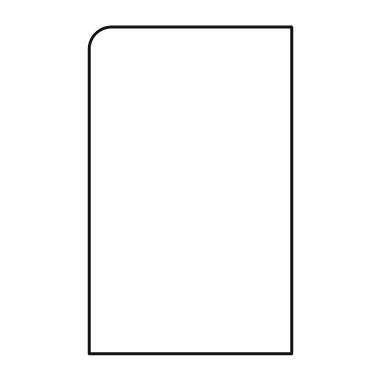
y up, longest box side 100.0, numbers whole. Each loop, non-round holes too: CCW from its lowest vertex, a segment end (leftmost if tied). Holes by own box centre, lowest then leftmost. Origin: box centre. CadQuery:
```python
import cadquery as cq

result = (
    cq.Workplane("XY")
    .moveTo(-31.0, -50.0)
    .lineTo(31.0, -50.0)
    .lineTo(31.0, 50.0)
    .lineTo(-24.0, 50.0)
    .threePointArc((-29.0, 48.0), (-31.0, 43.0))
    .close()
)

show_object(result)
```